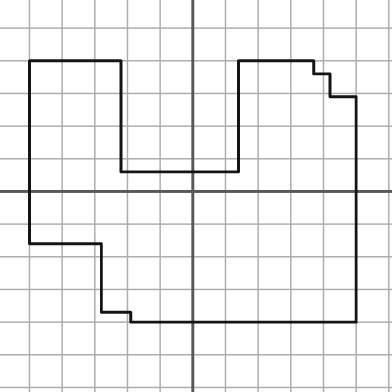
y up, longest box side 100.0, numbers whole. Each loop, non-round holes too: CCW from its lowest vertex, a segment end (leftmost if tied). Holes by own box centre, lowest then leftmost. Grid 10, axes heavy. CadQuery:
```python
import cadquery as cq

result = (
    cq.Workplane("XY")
    .moveTo(-19.0, -40.0)
    .lineTo(50.0, -40.0)
    .lineTo(50.0, 29.0)
    .lineTo(42.0, 29.0)
    .lineTo(42.0, 36.0)
    .lineTo(37.0, 36.0)
    .lineTo(37.0, 40.0)
    .lineTo(14.0, 40.0)
    .lineTo(14.0, 6.0)
    .lineTo(-22.0, 6.0)
    .lineTo(-22.0, 40.0)
    .lineTo(-50.0, 40.0)
    .lineTo(-50.0, -16.0)
    .lineTo(-28.0, -16.0)
    .lineTo(-28.0, -37.0)
    .lineTo(-19.0, -37.0)
    .close()
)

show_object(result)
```